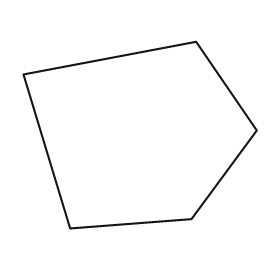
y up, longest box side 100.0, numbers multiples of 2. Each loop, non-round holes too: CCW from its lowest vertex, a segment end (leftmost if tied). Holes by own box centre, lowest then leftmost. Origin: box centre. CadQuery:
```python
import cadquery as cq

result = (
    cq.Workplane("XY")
    .moveTo(-30.0, -40.0)
    .lineTo(22.0, -36.0)
    .lineTo(50.0, 2.0)
    .lineTo(24.0, 40.0)
    .lineTo(-50.0, 26.0)
    .close()
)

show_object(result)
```